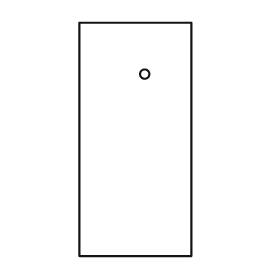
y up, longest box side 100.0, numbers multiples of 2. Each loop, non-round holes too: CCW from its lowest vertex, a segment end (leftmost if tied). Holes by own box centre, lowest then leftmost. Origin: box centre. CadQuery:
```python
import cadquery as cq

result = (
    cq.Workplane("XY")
    .moveTo(-24.0, -50.0)
    .lineTo(24.0, -50.0)
    .lineTo(24.0, 50.0)
    .lineTo(-24.0, 50.0)
    .close()
    .moveTo(4.0, 28.0)
    .circle(2.0)
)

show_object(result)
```